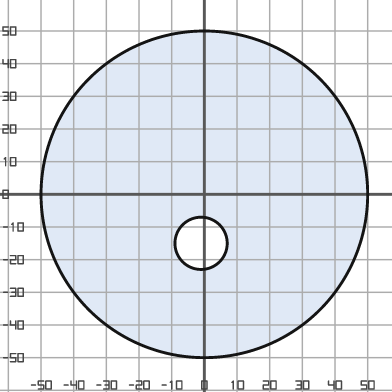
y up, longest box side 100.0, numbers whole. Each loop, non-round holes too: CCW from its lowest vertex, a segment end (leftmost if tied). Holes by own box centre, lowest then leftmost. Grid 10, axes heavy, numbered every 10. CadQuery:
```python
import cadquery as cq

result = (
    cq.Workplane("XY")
    .moveTo(0.0, 0.0)
    .circle(50.0)
    .moveTo(-1.0, -15.0)
    .circle(8.0)
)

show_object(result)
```